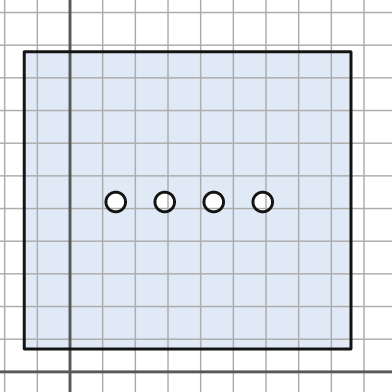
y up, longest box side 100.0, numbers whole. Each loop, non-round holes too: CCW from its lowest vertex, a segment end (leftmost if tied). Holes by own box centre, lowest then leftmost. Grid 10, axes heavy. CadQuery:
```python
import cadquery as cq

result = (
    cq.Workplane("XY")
    .moveTo(-14.0, 7.0)
    .lineTo(86.0, 7.0)
    .lineTo(86.0, 98.0)
    .lineTo(-14.0, 98.0)
    .close()
    .moveTo(14.0, 52.0)
    .circle(3.0)
    .moveTo(29.0, 52.0)
    .circle(3.0)
    .moveTo(44.0, 52.0)
    .circle(3.0)
    .moveTo(59.0, 52.0)
    .circle(3.0)
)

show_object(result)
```